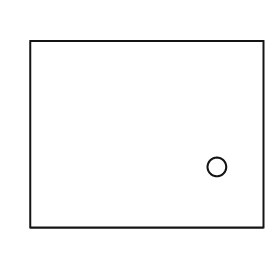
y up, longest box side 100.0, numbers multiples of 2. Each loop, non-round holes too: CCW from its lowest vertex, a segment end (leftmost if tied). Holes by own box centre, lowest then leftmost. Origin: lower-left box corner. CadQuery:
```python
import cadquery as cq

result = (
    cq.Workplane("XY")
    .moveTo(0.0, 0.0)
    .lineTo(100.0, 0.0)
    .lineTo(100.0, 80.0)
    .lineTo(0.0, 80.0)
    .close()
    .moveTo(80.0, 26.0)
    .circle(4.0)
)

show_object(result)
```